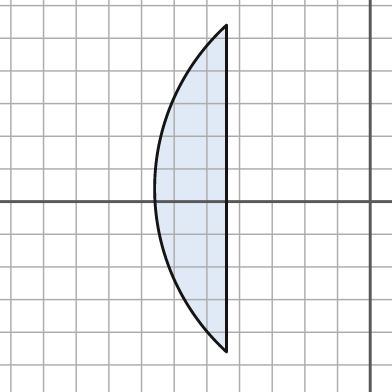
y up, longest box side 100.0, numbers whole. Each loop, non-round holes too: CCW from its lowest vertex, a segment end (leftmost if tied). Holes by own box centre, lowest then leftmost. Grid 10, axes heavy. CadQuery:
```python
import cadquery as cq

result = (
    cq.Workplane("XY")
    .moveTo(-44.0, -46.0)
    .lineTo(-44.0, 54.0)
    .threePointArc((-66.0, 4.0), (-44.0, -46.0))
    .close()
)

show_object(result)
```